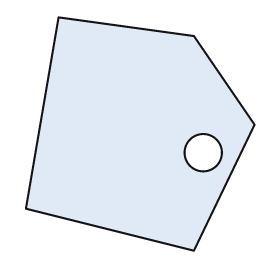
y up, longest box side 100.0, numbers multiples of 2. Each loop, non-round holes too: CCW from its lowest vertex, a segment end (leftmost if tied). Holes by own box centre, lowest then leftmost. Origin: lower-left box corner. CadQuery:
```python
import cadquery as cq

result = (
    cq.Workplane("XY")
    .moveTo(72.0, 0.0)
    .lineTo(98.0, 54.0)
    .lineTo(72.0, 92.0)
    .lineTo(14.0, 100.0)
    .lineTo(0.0, 18.0)
    .close()
    .moveTo(76.0, 42.0)
    .circle(8.0)
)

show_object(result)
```